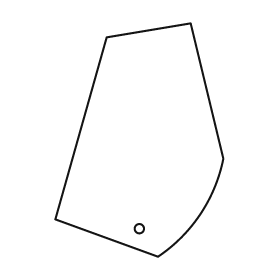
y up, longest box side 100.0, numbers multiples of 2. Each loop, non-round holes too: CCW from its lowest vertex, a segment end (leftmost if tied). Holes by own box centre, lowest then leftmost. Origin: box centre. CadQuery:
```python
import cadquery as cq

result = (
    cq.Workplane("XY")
    .moveTo(8.0, -50.0)
    .threePointArc((26.0, -32.0), (36.0, -8.0))
    .lineTo(22.0, 50.0)
    .lineTo(-14.0, 44.0)
    .lineTo(-36.0, -34.0)
    .close()
    .moveTo(0.0, -38.0)
    .circle(2.0)
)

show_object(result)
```